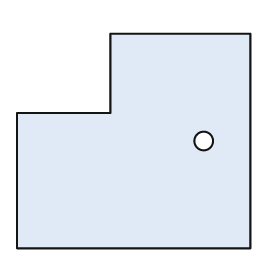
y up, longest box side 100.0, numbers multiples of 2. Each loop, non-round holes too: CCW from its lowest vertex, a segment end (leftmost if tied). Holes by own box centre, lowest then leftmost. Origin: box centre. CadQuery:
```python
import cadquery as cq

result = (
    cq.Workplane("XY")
    .moveTo(-50.0, -46.0)
    .lineTo(50.0, -46.0)
    .lineTo(50.0, 46.0)
    .lineTo(-10.0, 46.0)
    .lineTo(-10.0, 12.0)
    .lineTo(-50.0, 12.0)
    .close()
    .moveTo(30.0, 0.0)
    .circle(4.0)
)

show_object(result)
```